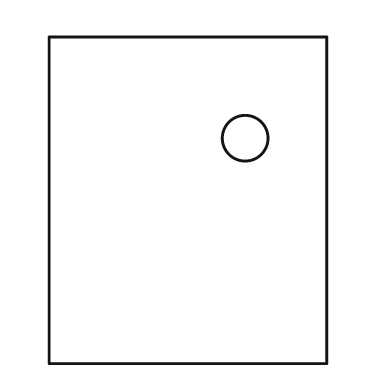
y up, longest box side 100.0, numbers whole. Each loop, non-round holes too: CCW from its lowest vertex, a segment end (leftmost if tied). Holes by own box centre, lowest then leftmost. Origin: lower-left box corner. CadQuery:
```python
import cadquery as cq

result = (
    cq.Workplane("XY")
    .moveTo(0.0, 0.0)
    .lineTo(85.0, 0.0)
    .lineTo(85.0, 100.0)
    .lineTo(0.0, 100.0)
    .close()
    .moveTo(60.0, 69.0)
    .circle(7.0)
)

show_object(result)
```